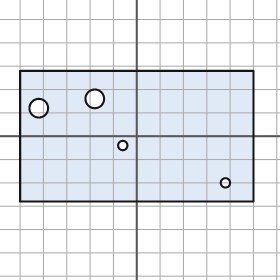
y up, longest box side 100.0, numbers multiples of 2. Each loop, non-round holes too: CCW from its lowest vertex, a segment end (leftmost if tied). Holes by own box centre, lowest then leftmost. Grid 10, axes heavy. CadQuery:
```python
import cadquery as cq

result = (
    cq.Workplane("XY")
    .moveTo(-50.0, -28.0)
    .lineTo(50.0, -28.0)
    .lineTo(50.0, 28.0)
    .lineTo(-50.0, 28.0)
    .close()
    .moveTo(38.0, -20.0)
    .circle(2.0)
    .moveTo(-6.0, -4.0)
    .circle(2.0)
    .moveTo(-42.0, 12.0)
    .circle(4.0)
    .moveTo(-18.0, 16.0)
    .circle(4.0)
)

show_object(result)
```